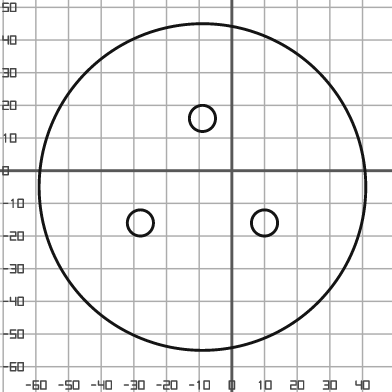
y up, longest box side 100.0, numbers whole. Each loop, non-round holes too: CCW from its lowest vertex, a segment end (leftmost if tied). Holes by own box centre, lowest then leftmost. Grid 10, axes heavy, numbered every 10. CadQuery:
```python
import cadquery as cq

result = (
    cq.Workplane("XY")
    .moveTo(-9.0, -5.0)
    .circle(50.0)
    .moveTo(-28.0, -16.0)
    .circle(4.0)
    .moveTo(10.0, -16.0)
    .circle(4.0)
    .moveTo(-9.0, 16.0)
    .circle(4.0)
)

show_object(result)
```